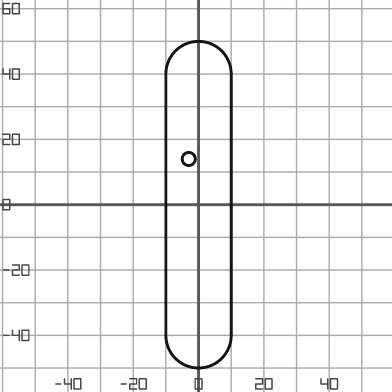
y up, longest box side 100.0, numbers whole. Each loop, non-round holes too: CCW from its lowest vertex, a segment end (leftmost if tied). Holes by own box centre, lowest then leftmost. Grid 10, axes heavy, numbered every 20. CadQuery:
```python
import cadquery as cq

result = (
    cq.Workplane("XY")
    .moveTo(-10.0, -40.0)
    .threePointArc((0.0, -50.0), (10.0, -40.0))
    .lineTo(10.0, 40.0)
    .threePointArc((0.0, 50.0), (-10.0, 40.0))
    .close()
    .moveTo(-3.0, 14.0)
    .circle(2.0)
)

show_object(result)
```